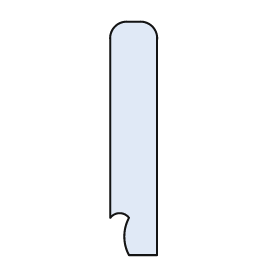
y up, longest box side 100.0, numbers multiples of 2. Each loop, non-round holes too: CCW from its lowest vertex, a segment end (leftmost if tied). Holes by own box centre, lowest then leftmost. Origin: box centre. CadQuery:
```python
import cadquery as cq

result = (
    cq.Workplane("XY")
    .moveTo(-2.0, -50.0)
    .lineTo(10.0, -50.0)
    .lineTo(10.0, 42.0)
    .threePointArc((8.0, 48.0), (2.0, 50.0))
    .lineTo(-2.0, 50.0)
    .threePointArc((-8.0, 48.0), (-10.0, 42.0))
    .lineTo(-10.0, -34.0)
    .threePointArc((-6.0, -32.0), (-2.0, -34.0))
    .threePointArc((-4.0, -42.0), (-2.0, -50.0))
    .close()
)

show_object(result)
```